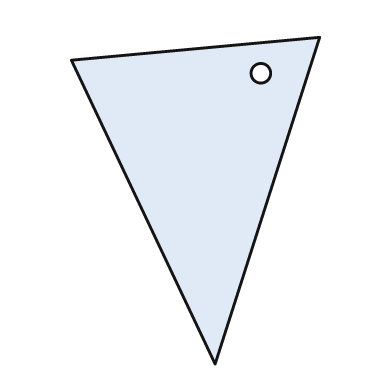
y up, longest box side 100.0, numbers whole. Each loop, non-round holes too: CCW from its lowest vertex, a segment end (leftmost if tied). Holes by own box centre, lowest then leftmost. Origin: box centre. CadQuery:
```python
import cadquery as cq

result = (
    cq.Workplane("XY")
    .moveTo(6.0, -50.0)
    .lineTo(38.0, 50.0)
    .lineTo(-38.0, 43.0)
    .close()
    .moveTo(20.0, 39.0)
    .circle(3.0)
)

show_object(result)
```